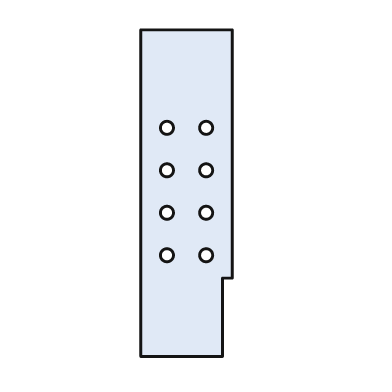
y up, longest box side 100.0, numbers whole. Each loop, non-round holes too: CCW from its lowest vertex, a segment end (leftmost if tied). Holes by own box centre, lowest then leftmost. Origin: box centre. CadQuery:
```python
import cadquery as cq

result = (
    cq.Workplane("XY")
    .moveTo(-14.0, -50.0)
    .lineTo(11.0, -50.0)
    .lineTo(11.0, -26.0)
    .lineTo(14.0, -26.0)
    .lineTo(14.0, 50.0)
    .lineTo(-14.0, 50.0)
    .close()
    .moveTo(-6.0, -19.0)
    .circle(2.0)
    .moveTo(6.0, -19.0)
    .circle(2.0)
    .moveTo(-6.0, -6.0)
    .circle(2.0)
    .moveTo(6.0, -6.0)
    .circle(2.0)
    .moveTo(-6.0, 7.0)
    .circle(2.0)
    .moveTo(6.0, 7.0)
    .circle(2.0)
    .moveTo(-6.0, 20.0)
    .circle(2.0)
    .moveTo(6.0, 20.0)
    .circle(2.0)
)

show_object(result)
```